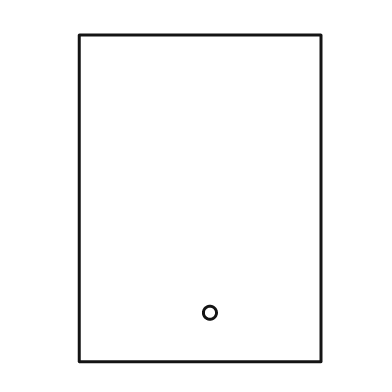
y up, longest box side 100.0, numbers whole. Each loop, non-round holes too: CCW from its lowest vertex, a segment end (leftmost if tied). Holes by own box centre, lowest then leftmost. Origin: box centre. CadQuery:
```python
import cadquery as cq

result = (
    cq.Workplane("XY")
    .moveTo(-37.0, -50.0)
    .lineTo(37.0, -50.0)
    .lineTo(37.0, 50.0)
    .lineTo(-37.0, 50.0)
    .close()
    .moveTo(3.0, -35.0)
    .circle(2.0)
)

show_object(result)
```